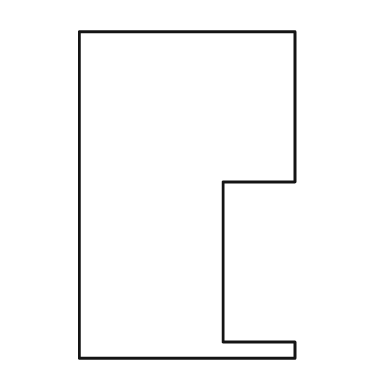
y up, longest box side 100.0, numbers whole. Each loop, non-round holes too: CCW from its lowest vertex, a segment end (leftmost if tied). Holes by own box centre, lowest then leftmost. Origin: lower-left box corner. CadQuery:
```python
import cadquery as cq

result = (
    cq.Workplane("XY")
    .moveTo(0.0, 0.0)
    .lineTo(66.0, 0.0)
    .lineTo(66.0, 5.0)
    .lineTo(44.0, 5.0)
    .lineTo(44.0, 54.0)
    .lineTo(66.0, 54.0)
    .lineTo(66.0, 100.0)
    .lineTo(0.0, 100.0)
    .close()
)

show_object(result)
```